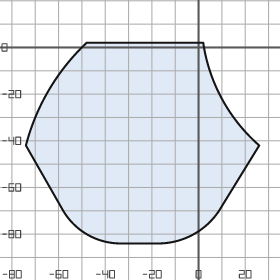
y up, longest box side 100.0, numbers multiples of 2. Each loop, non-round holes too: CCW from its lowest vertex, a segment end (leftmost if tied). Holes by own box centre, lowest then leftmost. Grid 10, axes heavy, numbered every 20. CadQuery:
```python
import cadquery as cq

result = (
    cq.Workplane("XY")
    .moveTo(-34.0, -84.0)
    .lineTo(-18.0, -84.0)
    .threePointArc((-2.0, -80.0), (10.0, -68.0))
    .lineTo(26.0, -42.0)
    .threePointArc((10.0, -22.0), (2.0, 2.0))
    .lineTo(-48.0, 2.0)
    .threePointArc((-64.0, -18.0), (-74.0, -42.0))
    .lineTo(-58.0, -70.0)
    .threePointArc((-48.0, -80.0), (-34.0, -84.0))
    .close()
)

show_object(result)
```